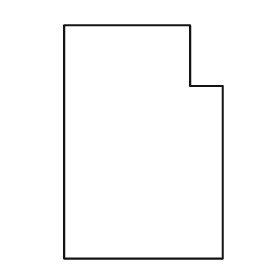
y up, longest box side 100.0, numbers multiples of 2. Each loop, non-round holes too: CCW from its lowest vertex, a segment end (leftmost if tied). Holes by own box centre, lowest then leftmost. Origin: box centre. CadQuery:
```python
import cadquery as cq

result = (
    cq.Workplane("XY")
    .moveTo(-34.0, -50.0)
    .lineTo(34.0, -50.0)
    .lineTo(34.0, 24.0)
    .lineTo(20.0, 24.0)
    .lineTo(20.0, 50.0)
    .lineTo(-34.0, 50.0)
    .close()
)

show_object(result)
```